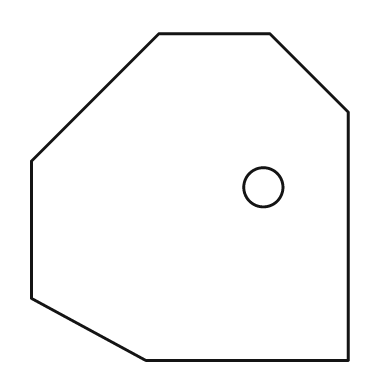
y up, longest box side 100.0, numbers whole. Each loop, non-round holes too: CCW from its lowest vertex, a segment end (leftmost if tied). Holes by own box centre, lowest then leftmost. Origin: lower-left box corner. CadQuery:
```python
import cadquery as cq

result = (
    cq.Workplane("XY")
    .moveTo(35.0, 0.0)
    .lineTo(97.0, 0.0)
    .lineTo(97.0, 76.0)
    .lineTo(73.0, 100.0)
    .lineTo(39.0, 100.0)
    .lineTo(0.0, 61.0)
    .lineTo(0.0, 19.0)
    .close()
    .moveTo(71.0, 53.0)
    .circle(6.0)
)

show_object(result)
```